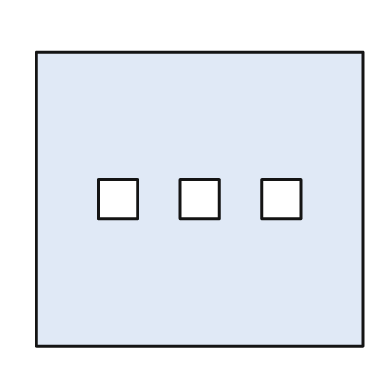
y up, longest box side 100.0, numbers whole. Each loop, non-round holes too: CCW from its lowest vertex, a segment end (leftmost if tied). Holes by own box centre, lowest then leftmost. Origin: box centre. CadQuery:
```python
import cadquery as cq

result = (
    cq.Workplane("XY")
    .moveTo(-50.0, -45.0)
    .lineTo(50.0, -45.0)
    .lineTo(50.0, 45.0)
    .lineTo(-50.0, 45.0)
    .close()
    .moveTo(-31.0, -6.0)
    .lineTo(-19.0, -6.0)
    .lineTo(-19.0, 6.0)
    .lineTo(-31.0, 6.0)
    .close()
    .moveTo(-6.0, -6.0)
    .lineTo(6.0, -6.0)
    .lineTo(6.0, 6.0)
    .lineTo(-6.0, 6.0)
    .close()
    .moveTo(19.0, -6.0)
    .lineTo(31.0, -6.0)
    .lineTo(31.0, 6.0)
    .lineTo(19.0, 6.0)
    .close()
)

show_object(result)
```